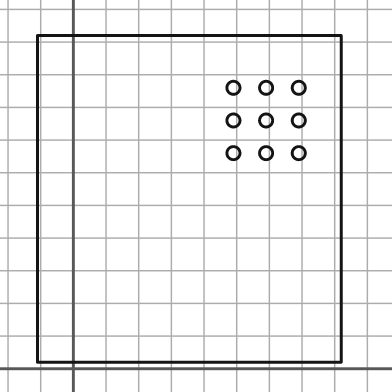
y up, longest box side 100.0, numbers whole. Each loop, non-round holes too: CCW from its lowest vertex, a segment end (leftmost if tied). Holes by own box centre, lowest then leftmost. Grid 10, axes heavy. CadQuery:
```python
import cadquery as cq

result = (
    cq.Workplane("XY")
    .moveTo(-11.0, 2.0)
    .lineTo(82.0, 2.0)
    .lineTo(82.0, 102.0)
    .lineTo(-11.0, 102.0)
    .close()
    .moveTo(49.0, 66.0)
    .circle(2.0)
    .moveTo(59.0, 66.0)
    .circle(2.0)
    .moveTo(69.0, 66.0)
    .circle(2.0)
    .moveTo(49.0, 76.0)
    .circle(2.0)
    .moveTo(59.0, 76.0)
    .circle(2.0)
    .moveTo(69.0, 76.0)
    .circle(2.0)
    .moveTo(49.0, 86.0)
    .circle(2.0)
    .moveTo(59.0, 86.0)
    .circle(2.0)
    .moveTo(69.0, 86.0)
    .circle(2.0)
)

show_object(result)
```